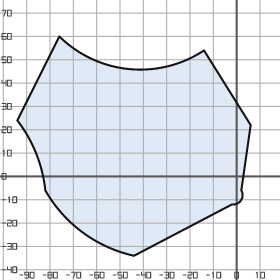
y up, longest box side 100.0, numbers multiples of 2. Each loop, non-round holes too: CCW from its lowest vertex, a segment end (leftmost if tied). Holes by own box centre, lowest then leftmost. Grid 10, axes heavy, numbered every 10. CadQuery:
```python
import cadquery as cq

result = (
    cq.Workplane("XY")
    .moveTo(-44.0, -34.0)
    .lineTo(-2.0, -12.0)
    .threePointArc((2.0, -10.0), (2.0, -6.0))
    .lineTo(6.0, 22.0)
    .lineTo(-14.0, 54.0)
    .threePointArc((-46.0, 46.0), (-76.0, 60.0))
    .lineTo(-94.0, 24.0)
    .threePointArc((-86.0, 10.0), (-82.0, -6.0))
    .threePointArc((-66.0, -24.0), (-44.0, -34.0))
    .close()
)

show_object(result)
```